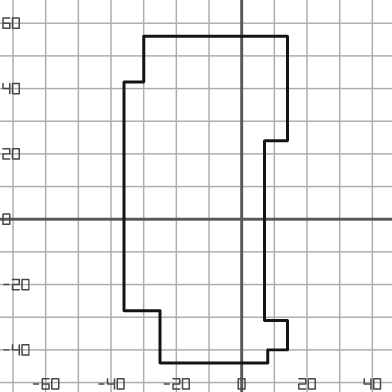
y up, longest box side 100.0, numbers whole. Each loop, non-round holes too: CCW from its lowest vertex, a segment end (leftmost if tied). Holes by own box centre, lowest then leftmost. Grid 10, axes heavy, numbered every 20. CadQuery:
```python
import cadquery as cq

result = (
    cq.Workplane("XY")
    .moveTo(-25.0, -44.0)
    .lineTo(8.0, -44.0)
    .lineTo(8.0, -40.0)
    .lineTo(14.0, -40.0)
    .lineTo(14.0, -31.0)
    .lineTo(7.0, -31.0)
    .lineTo(7.0, 24.0)
    .lineTo(14.0, 24.0)
    .lineTo(14.0, 56.0)
    .lineTo(-30.0, 56.0)
    .lineTo(-30.0, 42.0)
    .lineTo(-36.0, 42.0)
    .lineTo(-36.0, -28.0)
    .lineTo(-25.0, -28.0)
    .close()
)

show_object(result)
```